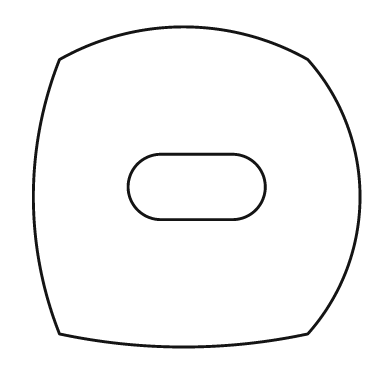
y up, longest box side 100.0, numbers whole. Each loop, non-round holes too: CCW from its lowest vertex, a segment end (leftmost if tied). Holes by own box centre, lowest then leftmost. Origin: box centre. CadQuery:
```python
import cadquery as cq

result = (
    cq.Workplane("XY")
    .moveTo(-42.0, -45.0)
    .threePointArc((-4.0, -49.0), (34.0, -45.0))
    .threePointArc((50.0, -3.0), (34.0, 39.0))
    .threePointArc((-4.0, 49.0), (-42.0, 39.0))
    .threePointArc((-50.0, -3.0), (-42.0, -45.0))
    .close()
    .moveTo(-11.0, -10.0)
    .lineTo(11.0, -10.0)
    .threePointArc((21.0, 0.0), (11.0, 10.0))
    .lineTo(-11.0, 10.0)
    .threePointArc((-21.0, 0.0), (-11.0, -10.0))
    .close()
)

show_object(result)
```